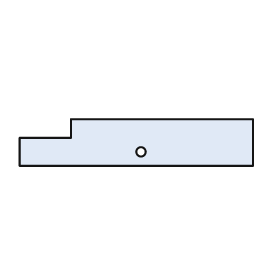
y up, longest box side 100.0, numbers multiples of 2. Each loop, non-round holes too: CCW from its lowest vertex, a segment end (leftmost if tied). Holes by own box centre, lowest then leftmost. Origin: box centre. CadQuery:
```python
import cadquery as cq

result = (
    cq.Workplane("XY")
    .moveTo(-50.0, -10.0)
    .lineTo(50.0, -10.0)
    .lineTo(50.0, 10.0)
    .lineTo(-28.0, 10.0)
    .lineTo(-28.0, 2.0)
    .lineTo(-50.0, 2.0)
    .close()
    .moveTo(2.0, -4.0)
    .circle(2.0)
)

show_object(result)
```